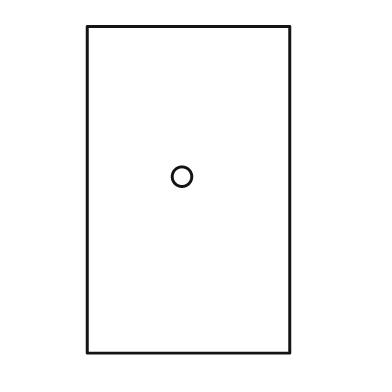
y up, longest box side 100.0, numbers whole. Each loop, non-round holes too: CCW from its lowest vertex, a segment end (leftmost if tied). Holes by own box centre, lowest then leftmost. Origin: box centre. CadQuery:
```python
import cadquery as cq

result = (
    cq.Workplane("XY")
    .moveTo(-31.0, -50.0)
    .lineTo(31.0, -50.0)
    .lineTo(31.0, 50.0)
    .lineTo(-31.0, 50.0)
    .close()
    .moveTo(-2.0, 4.0)
    .circle(3.0)
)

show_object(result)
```